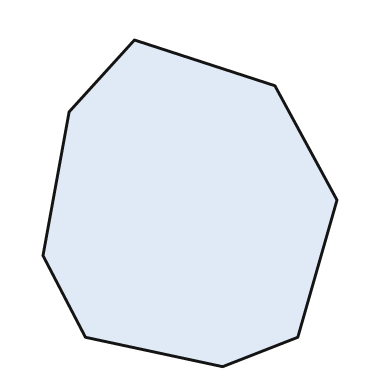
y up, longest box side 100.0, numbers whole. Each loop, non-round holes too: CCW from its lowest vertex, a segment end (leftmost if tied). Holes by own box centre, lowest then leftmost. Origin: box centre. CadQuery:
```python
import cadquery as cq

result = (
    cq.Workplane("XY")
    .moveTo(10.0, -50.0)
    .lineTo(33.0, -41.0)
    .lineTo(45.0, 1.0)
    .lineTo(26.0, 36.0)
    .lineTo(-17.0, 50.0)
    .lineTo(-37.0, 28.0)
    .lineTo(-45.0, -16.0)
    .lineTo(-32.0, -41.0)
    .close()
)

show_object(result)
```